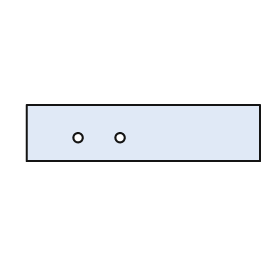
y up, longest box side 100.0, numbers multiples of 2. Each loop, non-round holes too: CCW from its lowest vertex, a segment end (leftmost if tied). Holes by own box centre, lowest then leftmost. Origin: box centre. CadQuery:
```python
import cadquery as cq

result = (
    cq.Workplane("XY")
    .moveTo(-50.0, -12.0)
    .lineTo(50.0, -12.0)
    .lineTo(50.0, 12.0)
    .lineTo(-50.0, 12.0)
    .close()
    .moveTo(-28.0, -2.0)
    .circle(2.0)
    .moveTo(-10.0, -2.0)
    .circle(2.0)
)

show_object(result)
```